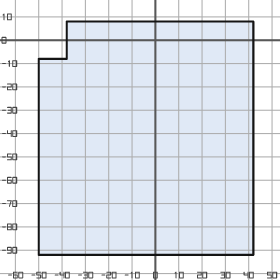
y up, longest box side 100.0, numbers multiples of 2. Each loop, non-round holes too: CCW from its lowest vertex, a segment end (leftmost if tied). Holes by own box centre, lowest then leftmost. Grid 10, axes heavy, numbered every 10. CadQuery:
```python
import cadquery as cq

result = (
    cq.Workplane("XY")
    .moveTo(-50.0, -92.0)
    .lineTo(42.0, -92.0)
    .lineTo(42.0, 8.0)
    .lineTo(-38.0, 8.0)
    .lineTo(-38.0, -8.0)
    .lineTo(-50.0, -8.0)
    .close()
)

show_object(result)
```